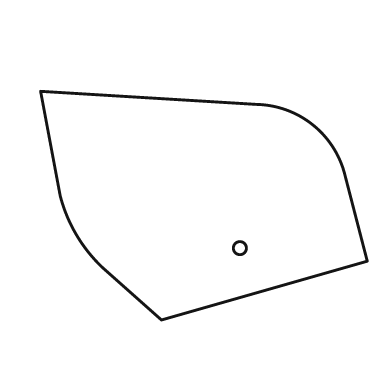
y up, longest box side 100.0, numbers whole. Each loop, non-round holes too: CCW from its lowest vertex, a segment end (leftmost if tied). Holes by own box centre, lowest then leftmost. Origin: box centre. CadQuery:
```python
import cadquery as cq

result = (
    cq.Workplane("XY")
    .moveTo(-13.0, -35.0)
    .lineTo(50.0, -17.0)
    .lineTo(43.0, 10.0)
    .threePointArc((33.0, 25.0), (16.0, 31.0))
    .lineTo(-50.0, 35.0)
    .lineTo(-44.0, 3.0)
    .threePointArc((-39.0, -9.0), (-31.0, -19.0))
    .close()
    .moveTo(11.0, -13.0)
    .circle(2.0)
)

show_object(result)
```